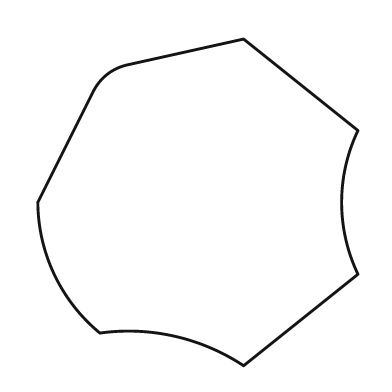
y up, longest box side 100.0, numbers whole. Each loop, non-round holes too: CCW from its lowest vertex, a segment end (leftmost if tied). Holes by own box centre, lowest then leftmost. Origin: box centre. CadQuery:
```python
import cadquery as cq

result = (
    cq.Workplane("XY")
    .moveTo(14.0, -50.0)
    .lineTo(49.0, -22.0)
    .threePointArc((44.0, 0.0), (49.0, 22.0))
    .lineTo(14.0, 50.0)
    .lineTo(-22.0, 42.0)
    .threePointArc((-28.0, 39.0), (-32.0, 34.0))
    .lineTo(-49.0, 0.0)
    .threePointArc((-44.0, -22.0), (-30.0, -40.0))
    .threePointArc((-7.0, -41.0), (14.0, -50.0))
    .close()
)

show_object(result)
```